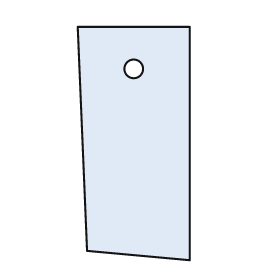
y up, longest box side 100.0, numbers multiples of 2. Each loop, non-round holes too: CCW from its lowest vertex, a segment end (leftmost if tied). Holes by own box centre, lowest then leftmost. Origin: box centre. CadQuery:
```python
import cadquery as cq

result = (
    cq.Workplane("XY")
    .moveTo(24.0, -50.0)
    .lineTo(24.0, 50.0)
    .lineTo(-24.0, 50.0)
    .lineTo(-20.0, -46.0)
    .close()
    .moveTo(0.0, 32.0)
    .circle(4.0)
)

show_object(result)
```